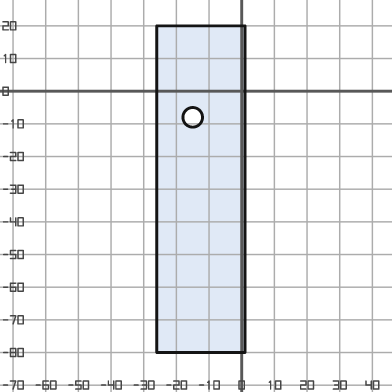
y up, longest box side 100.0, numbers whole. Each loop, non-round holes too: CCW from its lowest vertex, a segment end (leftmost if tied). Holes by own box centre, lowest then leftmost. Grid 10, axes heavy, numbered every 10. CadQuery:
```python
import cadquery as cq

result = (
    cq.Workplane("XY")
    .moveTo(-26.0, -80.0)
    .lineTo(1.0, -80.0)
    .lineTo(1.0, 20.0)
    .lineTo(-26.0, 20.0)
    .close()
    .moveTo(-15.0, -8.0)
    .circle(3.0)
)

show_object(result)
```